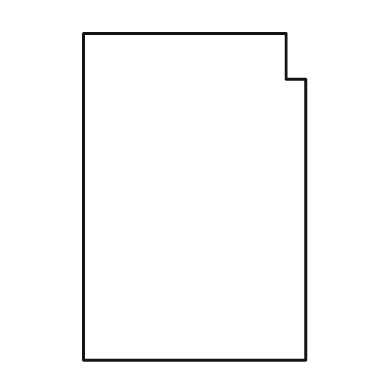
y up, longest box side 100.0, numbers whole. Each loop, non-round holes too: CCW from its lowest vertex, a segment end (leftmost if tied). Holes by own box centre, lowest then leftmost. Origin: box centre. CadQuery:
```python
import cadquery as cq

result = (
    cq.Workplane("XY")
    .moveTo(-34.0, -50.0)
    .lineTo(34.0, -50.0)
    .lineTo(34.0, 36.0)
    .lineTo(28.0, 36.0)
    .lineTo(28.0, 50.0)
    .lineTo(-34.0, 50.0)
    .close()
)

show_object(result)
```